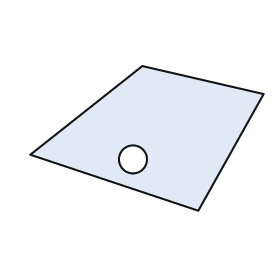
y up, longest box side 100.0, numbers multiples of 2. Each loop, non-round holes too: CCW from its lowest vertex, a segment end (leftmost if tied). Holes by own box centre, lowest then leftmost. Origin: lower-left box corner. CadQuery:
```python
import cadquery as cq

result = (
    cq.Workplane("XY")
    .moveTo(72.0, 0.0)
    .lineTo(100.0, 50.0)
    .lineTo(48.0, 62.0)
    .lineTo(0.0, 24.0)
    .close()
    .moveTo(44.0, 22.0)
    .circle(6.0)
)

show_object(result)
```